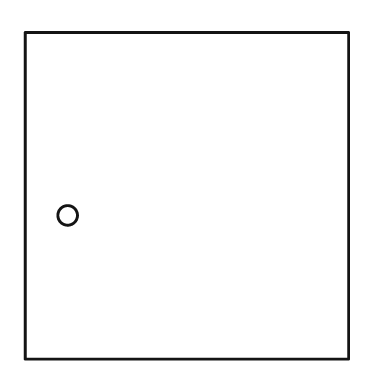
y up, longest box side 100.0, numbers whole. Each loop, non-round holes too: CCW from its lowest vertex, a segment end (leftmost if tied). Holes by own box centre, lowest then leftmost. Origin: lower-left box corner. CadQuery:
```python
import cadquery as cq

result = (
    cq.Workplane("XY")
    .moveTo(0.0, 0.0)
    .lineTo(99.0, 0.0)
    .lineTo(99.0, 100.0)
    .lineTo(0.0, 100.0)
    .close()
    .moveTo(13.0, 44.0)
    .circle(3.0)
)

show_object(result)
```